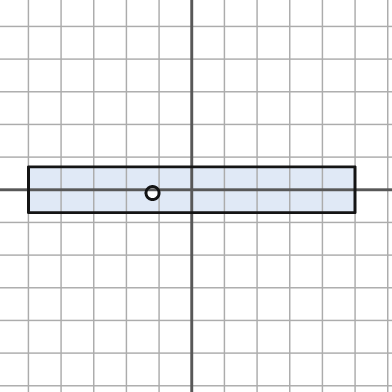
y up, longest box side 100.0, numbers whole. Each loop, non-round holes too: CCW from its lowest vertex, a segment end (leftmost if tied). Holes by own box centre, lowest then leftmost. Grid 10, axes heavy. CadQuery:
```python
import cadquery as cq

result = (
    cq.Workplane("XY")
    .moveTo(-50.0, -7.0)
    .lineTo(50.0, -7.0)
    .lineTo(50.0, 7.0)
    .lineTo(-50.0, 7.0)
    .close()
    .moveTo(-12.0, -1.0)
    .circle(2.0)
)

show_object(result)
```